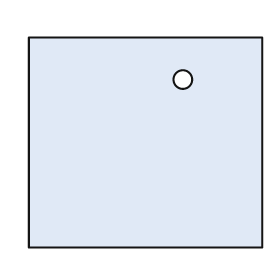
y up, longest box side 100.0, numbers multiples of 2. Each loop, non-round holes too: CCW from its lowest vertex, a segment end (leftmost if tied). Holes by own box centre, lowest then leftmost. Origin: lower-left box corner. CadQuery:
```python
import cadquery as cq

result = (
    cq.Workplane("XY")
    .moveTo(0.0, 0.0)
    .lineTo(100.0, 0.0)
    .lineTo(100.0, 90.0)
    .lineTo(0.0, 90.0)
    .close()
    .moveTo(66.0, 72.0)
    .circle(4.0)
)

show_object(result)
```